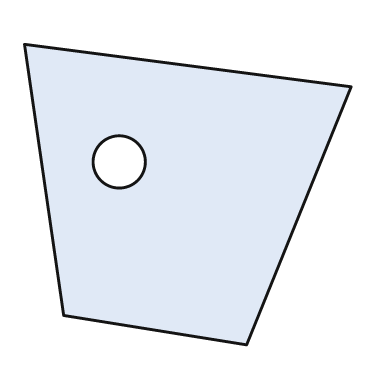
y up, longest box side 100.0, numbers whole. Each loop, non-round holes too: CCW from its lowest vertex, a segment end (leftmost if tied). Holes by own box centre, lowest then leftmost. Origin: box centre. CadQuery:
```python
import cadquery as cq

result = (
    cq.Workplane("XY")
    .moveTo(18.0, -46.0)
    .lineTo(50.0, 33.0)
    .lineTo(-50.0, 46.0)
    .lineTo(-38.0, -37.0)
    .close()
    .moveTo(-21.0, 10.0)
    .circle(8.0)
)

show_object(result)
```